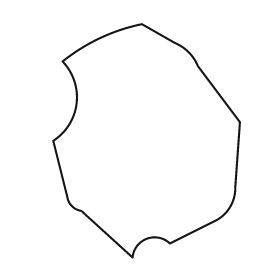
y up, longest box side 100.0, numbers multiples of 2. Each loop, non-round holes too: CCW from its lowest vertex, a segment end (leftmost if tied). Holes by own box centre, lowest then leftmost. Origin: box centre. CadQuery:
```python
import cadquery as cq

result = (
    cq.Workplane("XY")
    .moveTo(-6.0, -50.0)
    .threePointArc((0.0, -42.0), (10.0, -44.0))
    .lineTo(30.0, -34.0)
    .threePointArc((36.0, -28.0), (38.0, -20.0))
    .lineTo(40.0, 8.0)
    .lineTo(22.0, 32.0)
    .threePointArc((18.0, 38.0), (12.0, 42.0))
    .lineTo(-2.0, 50.0)
    .threePointArc((-20.0, 44.0), (-36.0, 34.0))
    .threePointArc((-30.0, 16.0), (-40.0, 0.0))
    .lineTo(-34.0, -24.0)
    .threePointArc((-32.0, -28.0), (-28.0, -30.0))
    .close()
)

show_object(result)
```